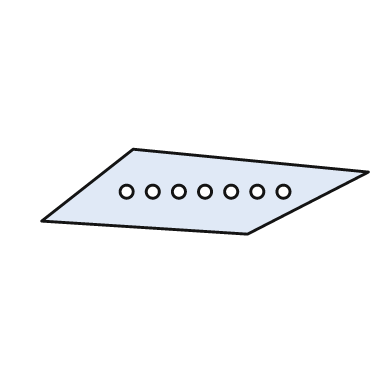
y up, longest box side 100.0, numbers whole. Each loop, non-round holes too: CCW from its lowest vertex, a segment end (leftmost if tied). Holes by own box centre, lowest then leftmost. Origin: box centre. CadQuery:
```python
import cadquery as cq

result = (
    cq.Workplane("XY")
    .moveTo(13.0, -13.0)
    .lineTo(50.0, 6.0)
    .lineTo(-22.0, 13.0)
    .lineTo(-50.0, -9.0)
    .close()
    .moveTo(-24.0, 0.0)
    .circle(2.0)
    .moveTo(-16.0, 0.0)
    .circle(2.0)
    .moveTo(-8.0, 0.0)
    .circle(2.0)
    .moveTo(0.0, 0.0)
    .circle(2.0)
    .moveTo(8.0, 0.0)
    .circle(2.0)
    .moveTo(16.0, 0.0)
    .circle(2.0)
    .moveTo(24.0, 0.0)
    .circle(2.0)
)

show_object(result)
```